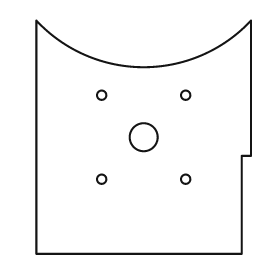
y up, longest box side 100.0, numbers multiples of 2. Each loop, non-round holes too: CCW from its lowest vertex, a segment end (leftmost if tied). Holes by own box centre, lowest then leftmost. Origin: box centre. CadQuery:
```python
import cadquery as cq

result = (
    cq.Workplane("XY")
    .moveTo(-46.0, -50.0)
    .lineTo(42.0, -50.0)
    .lineTo(42.0, -8.0)
    .lineTo(46.0, -8.0)
    .lineTo(46.0, 50.0)
    .threePointArc((0.0, 30.0), (-46.0, 50.0))
    .close()
    .moveTo(-18.0, -18.0)
    .circle(2.0)
    .moveTo(18.0, -18.0)
    .circle(2.0)
    .moveTo(0.0, 0.0)
    .circle(6.0)
    .moveTo(-18.0, 18.0)
    .circle(2.0)
    .moveTo(18.0, 18.0)
    .circle(2.0)
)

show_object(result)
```